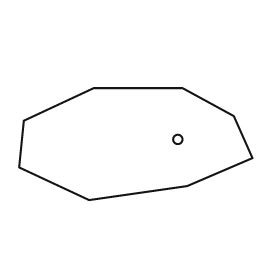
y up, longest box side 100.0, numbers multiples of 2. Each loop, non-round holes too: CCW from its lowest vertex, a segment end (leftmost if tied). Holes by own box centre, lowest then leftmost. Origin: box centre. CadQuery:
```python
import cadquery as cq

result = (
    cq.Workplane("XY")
    .moveTo(-20.0, -24.0)
    .lineTo(22.0, -18.0)
    .lineTo(50.0, -6.0)
    .lineTo(42.0, 12.0)
    .lineTo(20.0, 24.0)
    .lineTo(-18.0, 24.0)
    .lineTo(-48.0, 10.0)
    .lineTo(-50.0, -10.0)
    .close()
    .moveTo(18.0, 2.0)
    .circle(2.0)
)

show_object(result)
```